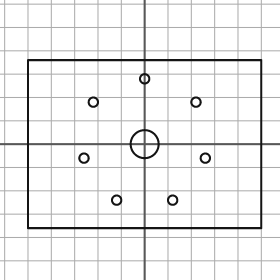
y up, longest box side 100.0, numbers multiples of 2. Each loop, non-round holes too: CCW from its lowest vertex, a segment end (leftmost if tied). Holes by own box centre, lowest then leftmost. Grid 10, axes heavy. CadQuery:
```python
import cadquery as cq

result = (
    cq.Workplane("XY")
    .moveTo(-50.0, -36.0)
    .lineTo(50.0, -36.0)
    .lineTo(50.0, 36.0)
    .lineTo(-50.0, 36.0)
    .close()
    .moveTo(-12.0, -24.0)
    .circle(2.0)
    .moveTo(12.0, -24.0)
    .circle(2.0)
    .moveTo(-26.0, -6.0)
    .circle(2.0)
    .moveTo(26.0, -6.0)
    .circle(2.0)
    .moveTo(0.0, 0.0)
    .circle(6.0)
    .moveTo(-22.0, 18.0)
    .circle(2.0)
    .moveTo(22.0, 18.0)
    .circle(2.0)
    .moveTo(0.0, 28.0)
    .circle(2.0)
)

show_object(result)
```